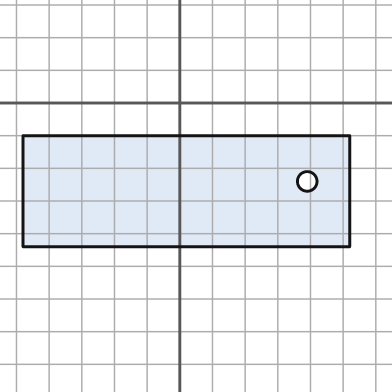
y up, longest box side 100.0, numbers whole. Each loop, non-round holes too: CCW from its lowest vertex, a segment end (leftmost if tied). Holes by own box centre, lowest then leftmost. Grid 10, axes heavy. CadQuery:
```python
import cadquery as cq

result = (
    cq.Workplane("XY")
    .moveTo(-48.0, -44.0)
    .lineTo(52.0, -44.0)
    .lineTo(52.0, -10.0)
    .lineTo(-48.0, -10.0)
    .close()
    .moveTo(39.0, -24.0)
    .circle(3.0)
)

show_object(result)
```